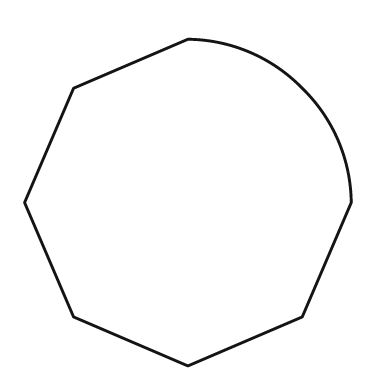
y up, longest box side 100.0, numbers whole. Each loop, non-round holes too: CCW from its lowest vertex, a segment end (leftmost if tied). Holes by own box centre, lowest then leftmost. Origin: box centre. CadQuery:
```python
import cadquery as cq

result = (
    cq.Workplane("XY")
    .moveTo(0.0, -50.0)
    .lineTo(35.0, -35.0)
    .lineTo(50.0, 0.0)
    .threePointArc((46.0, 19.0), (35.0, 35.0))
    .threePointArc((19.0, 46.0), (0.0, 50.0))
    .lineTo(-35.0, 35.0)
    .lineTo(-50.0, 0.0)
    .lineTo(-35.0, -35.0)
    .close()
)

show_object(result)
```